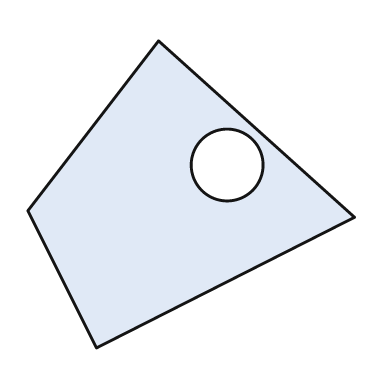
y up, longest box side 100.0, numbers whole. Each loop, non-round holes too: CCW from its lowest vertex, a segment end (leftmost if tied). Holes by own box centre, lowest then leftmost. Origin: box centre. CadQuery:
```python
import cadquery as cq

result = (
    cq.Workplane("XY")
    .moveTo(-29.0, -47.0)
    .lineTo(50.0, -7.0)
    .lineTo(-10.0, 47.0)
    .lineTo(-50.0, -5.0)
    .close()
    .moveTo(11.0, 9.0)
    .circle(11.0)
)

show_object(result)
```